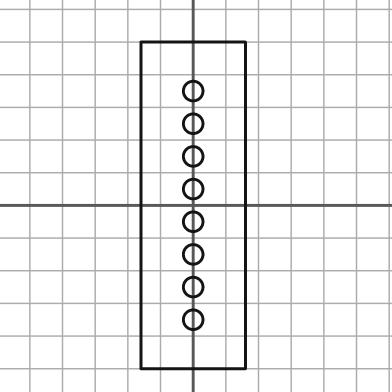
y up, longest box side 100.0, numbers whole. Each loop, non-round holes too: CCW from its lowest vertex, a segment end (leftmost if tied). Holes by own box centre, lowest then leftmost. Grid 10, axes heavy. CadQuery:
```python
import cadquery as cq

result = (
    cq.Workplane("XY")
    .moveTo(-16.0, -50.0)
    .lineTo(16.0, -50.0)
    .lineTo(16.0, 50.0)
    .lineTo(-16.0, 50.0)
    .close()
    .moveTo(0.0, -35.0)
    .circle(3.0)
    .moveTo(0.0, -25.0)
    .circle(3.0)
    .moveTo(0.0, -15.0)
    .circle(3.0)
    .moveTo(0.0, -5.0)
    .circle(3.0)
    .moveTo(0.0, 5.0)
    .circle(3.0)
    .moveTo(0.0, 15.0)
    .circle(3.0)
    .moveTo(0.0, 25.0)
    .circle(3.0)
    .moveTo(0.0, 35.0)
    .circle(3.0)
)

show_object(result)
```